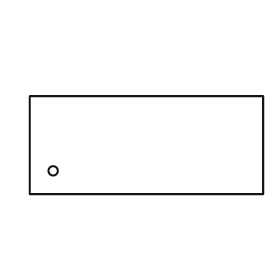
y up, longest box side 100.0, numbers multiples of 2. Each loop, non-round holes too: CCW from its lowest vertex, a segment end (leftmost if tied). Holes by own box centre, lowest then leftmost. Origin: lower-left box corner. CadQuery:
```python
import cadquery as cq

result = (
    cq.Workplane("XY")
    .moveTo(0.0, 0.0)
    .lineTo(100.0, 0.0)
    .lineTo(100.0, 42.0)
    .lineTo(0.0, 42.0)
    .close()
    .moveTo(10.0, 10.0)
    .circle(2.0)
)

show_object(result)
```